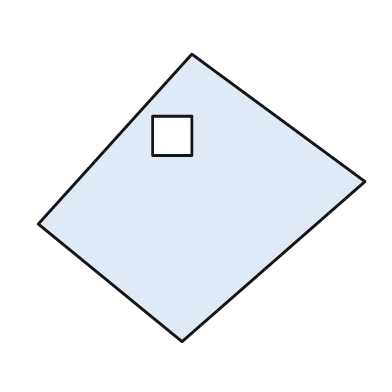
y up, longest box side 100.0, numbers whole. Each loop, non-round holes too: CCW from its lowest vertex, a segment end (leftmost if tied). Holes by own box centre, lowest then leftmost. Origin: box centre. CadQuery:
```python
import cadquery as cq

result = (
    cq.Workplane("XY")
    .moveTo(-6.0, -44.0)
    .lineTo(50.0, 5.0)
    .lineTo(-3.0, 44.0)
    .lineTo(-50.0, -8.0)
    .close()
    .moveTo(-15.0, 13.0)
    .lineTo(-3.0, 13.0)
    .lineTo(-3.0, 25.0)
    .lineTo(-15.0, 25.0)
    .close()
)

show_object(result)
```